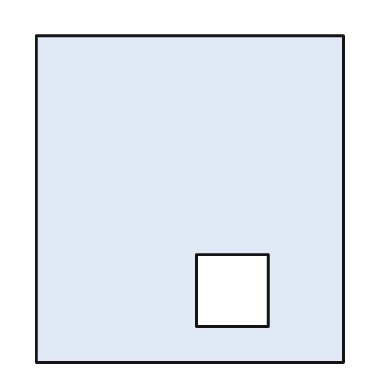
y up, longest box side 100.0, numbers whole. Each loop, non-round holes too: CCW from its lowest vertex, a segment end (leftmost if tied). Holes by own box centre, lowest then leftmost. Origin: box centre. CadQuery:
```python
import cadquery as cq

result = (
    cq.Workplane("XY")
    .moveTo(-47.0, -50.0)
    .lineTo(47.0, -50.0)
    .lineTo(47.0, 50.0)
    .lineTo(-47.0, 50.0)
    .close()
    .moveTo(2.0, -39.0)
    .lineTo(24.0, -39.0)
    .lineTo(24.0, -17.0)
    .lineTo(2.0, -17.0)
    .close()
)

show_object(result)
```